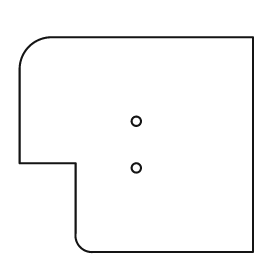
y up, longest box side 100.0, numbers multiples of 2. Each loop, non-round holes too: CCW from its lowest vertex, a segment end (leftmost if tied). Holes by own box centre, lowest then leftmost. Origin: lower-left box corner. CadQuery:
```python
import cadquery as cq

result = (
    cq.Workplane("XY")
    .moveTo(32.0, 0.0)
    .lineTo(100.0, 0.0)
    .lineTo(100.0, 92.0)
    .lineTo(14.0, 92.0)
    .threePointArc((4.0, 88.0), (0.0, 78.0))
    .lineTo(0.0, 38.0)
    .lineTo(24.0, 38.0)
    .lineTo(24.0, 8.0)
    .threePointArc((26.0, 2.0), (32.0, 0.0))
    .close()
    .moveTo(50.0, 36.0)
    .circle(2.0)
    .moveTo(50.0, 56.0)
    .circle(2.0)
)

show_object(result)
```